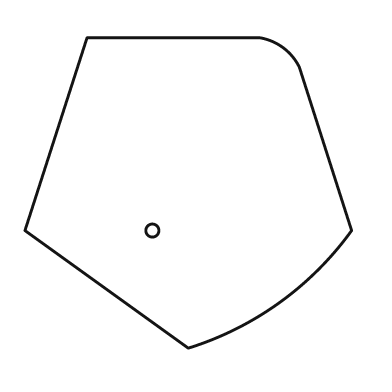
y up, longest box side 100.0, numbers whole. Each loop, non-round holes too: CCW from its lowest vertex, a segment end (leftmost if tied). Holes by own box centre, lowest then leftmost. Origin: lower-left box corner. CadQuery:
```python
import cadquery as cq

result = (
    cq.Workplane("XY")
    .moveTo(50.0, 0.0)
    .threePointArc((78.0, 14.0), (100.0, 36.0))
    .lineTo(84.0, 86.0)
    .threePointArc((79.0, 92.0), (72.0, 95.0))
    .lineTo(19.0, 95.0)
    .lineTo(0.0, 36.0)
    .close()
    .moveTo(39.0, 36.0)
    .circle(2.0)
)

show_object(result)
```